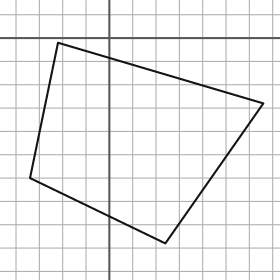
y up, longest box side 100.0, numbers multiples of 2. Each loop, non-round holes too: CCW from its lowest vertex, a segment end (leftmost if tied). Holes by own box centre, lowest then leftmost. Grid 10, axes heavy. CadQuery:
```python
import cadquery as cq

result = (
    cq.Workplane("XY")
    .moveTo(24.0, -88.0)
    .lineTo(66.0, -28.0)
    .lineTo(-22.0, -2.0)
    .lineTo(-34.0, -60.0)
    .close()
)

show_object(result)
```